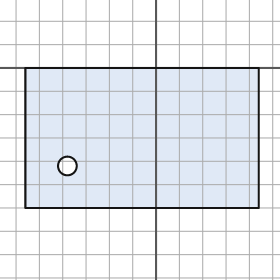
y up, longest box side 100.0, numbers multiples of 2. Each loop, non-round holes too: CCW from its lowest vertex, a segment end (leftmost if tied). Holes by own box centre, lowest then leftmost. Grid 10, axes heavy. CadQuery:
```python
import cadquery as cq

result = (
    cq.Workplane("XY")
    .moveTo(-56.0, -60.0)
    .lineTo(44.0, -60.0)
    .lineTo(44.0, 0.0)
    .lineTo(-56.0, 0.0)
    .close()
    .moveTo(-38.0, -42.0)
    .circle(4.0)
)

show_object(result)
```